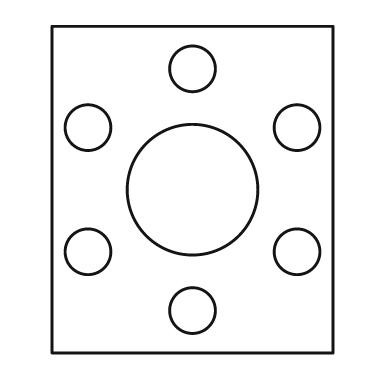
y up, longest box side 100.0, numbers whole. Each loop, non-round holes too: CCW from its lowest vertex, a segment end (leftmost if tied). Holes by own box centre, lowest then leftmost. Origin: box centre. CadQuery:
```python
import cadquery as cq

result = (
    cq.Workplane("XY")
    .moveTo(-43.0, -50.0)
    .lineTo(43.0, -50.0)
    .lineTo(43.0, 50.0)
    .lineTo(-43.0, 50.0)
    .close()
    .moveTo(0.0, -37.0)
    .circle(7.0)
    .moveTo(-32.0, -19.0)
    .circle(7.0)
    .moveTo(32.0, -19.0)
    .circle(7.0)
    .moveTo(0.0, 0.0)
    .circle(20.0)
    .moveTo(-32.0, 19.0)
    .circle(7.0)
    .moveTo(32.0, 19.0)
    .circle(7.0)
    .moveTo(0.0, 37.0)
    .circle(7.0)
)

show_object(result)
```